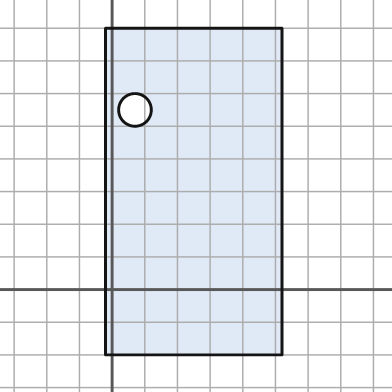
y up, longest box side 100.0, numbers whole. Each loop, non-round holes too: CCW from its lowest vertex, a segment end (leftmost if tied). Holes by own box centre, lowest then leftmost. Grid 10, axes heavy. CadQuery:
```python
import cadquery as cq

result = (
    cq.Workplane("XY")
    .moveTo(-2.0, -20.0)
    .lineTo(52.0, -20.0)
    .lineTo(52.0, 80.0)
    .lineTo(-2.0, 80.0)
    .close()
    .moveTo(7.0, 55.0)
    .circle(5.0)
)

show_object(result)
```